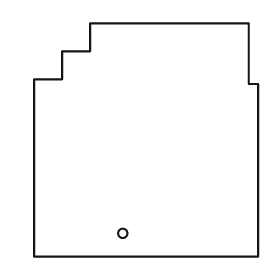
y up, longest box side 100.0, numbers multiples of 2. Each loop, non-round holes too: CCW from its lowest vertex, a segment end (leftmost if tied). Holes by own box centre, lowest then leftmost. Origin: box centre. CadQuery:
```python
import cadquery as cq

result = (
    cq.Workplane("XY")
    .moveTo(-48.0, -50.0)
    .lineTo(48.0, -50.0)
    .lineTo(48.0, 24.0)
    .lineTo(44.0, 24.0)
    .lineTo(44.0, 50.0)
    .lineTo(-24.0, 50.0)
    .lineTo(-24.0, 38.0)
    .lineTo(-36.0, 38.0)
    .lineTo(-36.0, 26.0)
    .lineTo(-48.0, 26.0)
    .close()
    .moveTo(-10.0, -40.0)
    .circle(2.0)
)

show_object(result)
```